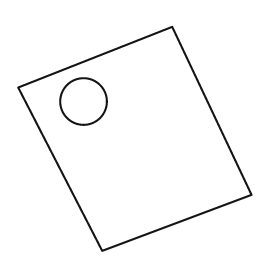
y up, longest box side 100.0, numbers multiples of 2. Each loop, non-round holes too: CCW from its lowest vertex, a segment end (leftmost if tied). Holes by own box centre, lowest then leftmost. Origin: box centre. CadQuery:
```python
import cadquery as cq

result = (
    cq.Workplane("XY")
    .moveTo(-14.0, -48.0)
    .lineTo(50.0, -24.0)
    .lineTo(16.0, 48.0)
    .lineTo(-50.0, 22.0)
    .close()
    .moveTo(-22.0, 16.0)
    .circle(10.0)
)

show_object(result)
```